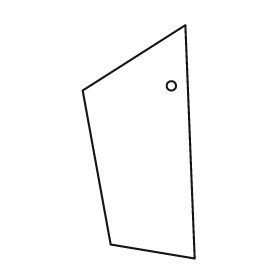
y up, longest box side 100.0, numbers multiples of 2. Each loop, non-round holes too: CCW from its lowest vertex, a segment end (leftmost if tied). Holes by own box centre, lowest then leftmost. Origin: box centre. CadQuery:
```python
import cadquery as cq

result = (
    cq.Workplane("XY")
    .moveTo(24.0, -50.0)
    .lineTo(20.0, 50.0)
    .lineTo(-24.0, 22.0)
    .lineTo(-12.0, -44.0)
    .close()
    .moveTo(14.0, 24.0)
    .circle(2.0)
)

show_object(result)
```